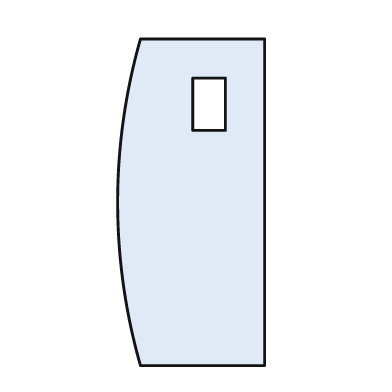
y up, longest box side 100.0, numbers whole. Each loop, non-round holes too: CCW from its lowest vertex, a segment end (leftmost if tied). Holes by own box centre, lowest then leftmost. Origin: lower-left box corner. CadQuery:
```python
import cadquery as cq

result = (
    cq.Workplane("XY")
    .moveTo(7.0, 0.0)
    .lineTo(45.0, 0.0)
    .lineTo(45.0, 100.0)
    .lineTo(7.0, 100.0)
    .threePointArc((0.0, 50.0), (7.0, 0.0))
    .close()
    .moveTo(23.0, 72.0)
    .lineTo(33.0, 72.0)
    .lineTo(33.0, 88.0)
    .lineTo(23.0, 88.0)
    .close()
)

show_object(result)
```